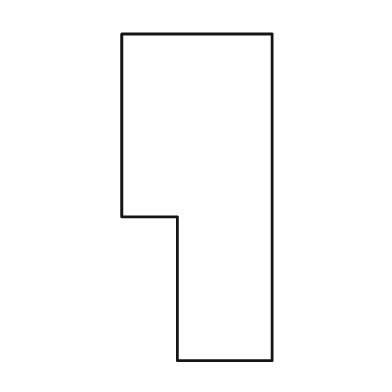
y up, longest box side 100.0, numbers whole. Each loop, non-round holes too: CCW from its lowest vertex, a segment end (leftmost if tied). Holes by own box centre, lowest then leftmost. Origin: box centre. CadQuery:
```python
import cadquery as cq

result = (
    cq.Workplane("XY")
    .moveTo(-6.0, -50.0)
    .lineTo(23.0, -50.0)
    .lineTo(23.0, 50.0)
    .lineTo(-23.0, 50.0)
    .lineTo(-23.0, -6.0)
    .lineTo(-6.0, -6.0)
    .close()
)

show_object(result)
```